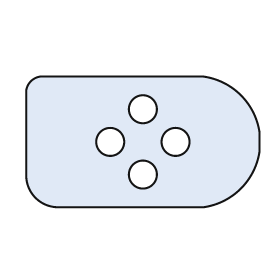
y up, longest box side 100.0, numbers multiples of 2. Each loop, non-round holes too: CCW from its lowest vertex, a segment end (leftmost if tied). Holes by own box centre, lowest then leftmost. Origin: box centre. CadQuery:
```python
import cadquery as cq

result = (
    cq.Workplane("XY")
    .moveTo(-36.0, -28.0)
    .lineTo(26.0, -28.0)
    .threePointArc((42.0, -20.0), (50.0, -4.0))
    .lineTo(50.0, 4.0)
    .threePointArc((42.0, 20.0), (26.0, 28.0))
    .lineTo(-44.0, 28.0)
    .threePointArc((-48.0, 26.0), (-50.0, 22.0))
    .lineTo(-50.0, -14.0)
    .threePointArc((-46.0, -24.0), (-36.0, -28.0))
    .close()
    .moveTo(0.0, -14.0)
    .circle(6.0)
    .moveTo(-14.0, 0.0)
    .circle(6.0)
    .moveTo(14.0, 0.0)
    .circle(6.0)
    .moveTo(0.0, 14.0)
    .circle(6.0)
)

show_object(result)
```